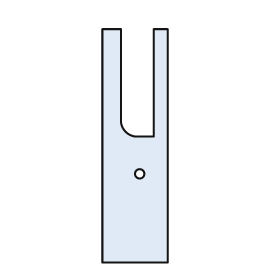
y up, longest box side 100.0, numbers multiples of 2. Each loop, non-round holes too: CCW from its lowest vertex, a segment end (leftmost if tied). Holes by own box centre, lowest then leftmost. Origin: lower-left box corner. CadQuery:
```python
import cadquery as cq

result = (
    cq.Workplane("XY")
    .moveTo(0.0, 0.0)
    .lineTo(28.0, 0.0)
    .lineTo(28.0, 100.0)
    .lineTo(22.0, 100.0)
    .lineTo(22.0, 54.0)
    .lineTo(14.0, 54.0)
    .threePointArc((10.0, 56.0), (8.0, 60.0))
    .lineTo(8.0, 100.0)
    .lineTo(0.0, 100.0)
    .close()
    .moveTo(16.0, 38.0)
    .circle(2.0)
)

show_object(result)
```